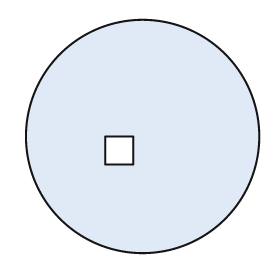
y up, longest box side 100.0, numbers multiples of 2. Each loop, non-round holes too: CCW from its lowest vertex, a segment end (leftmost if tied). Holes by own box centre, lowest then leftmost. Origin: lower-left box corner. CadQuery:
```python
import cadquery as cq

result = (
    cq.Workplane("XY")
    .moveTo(50.0, 50.0)
    .circle(50.0)
    .moveTo(34.0, 38.0)
    .lineTo(46.0, 38.0)
    .lineTo(46.0, 50.0)
    .lineTo(34.0, 50.0)
    .close()
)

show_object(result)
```